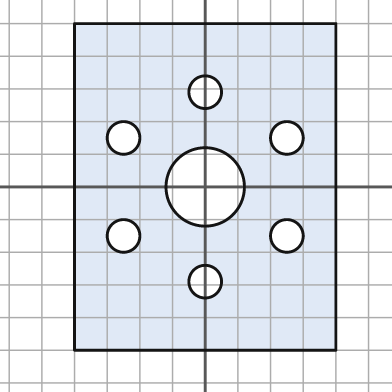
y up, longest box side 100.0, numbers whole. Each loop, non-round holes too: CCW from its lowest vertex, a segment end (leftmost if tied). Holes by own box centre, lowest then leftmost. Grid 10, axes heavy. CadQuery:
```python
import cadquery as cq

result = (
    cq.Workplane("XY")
    .moveTo(-40.0, -50.0)
    .lineTo(40.0, -50.0)
    .lineTo(40.0, 50.0)
    .lineTo(-40.0, 50.0)
    .close()
    .moveTo(0.0, -29.0)
    .circle(5.0)
    .moveTo(-25.0, -15.0)
    .circle(5.0)
    .moveTo(25.0, -15.0)
    .circle(5.0)
    .moveTo(0.0, 0.0)
    .circle(12.0)
    .moveTo(-25.0, 15.0)
    .circle(5.0)
    .moveTo(25.0, 15.0)
    .circle(5.0)
    .moveTo(0.0, 29.0)
    .circle(5.0)
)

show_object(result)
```